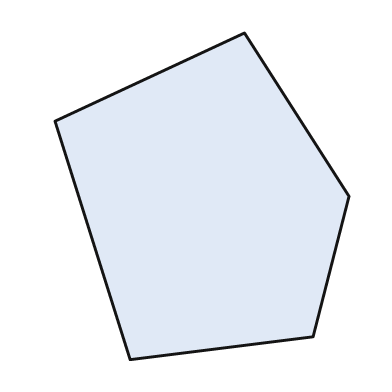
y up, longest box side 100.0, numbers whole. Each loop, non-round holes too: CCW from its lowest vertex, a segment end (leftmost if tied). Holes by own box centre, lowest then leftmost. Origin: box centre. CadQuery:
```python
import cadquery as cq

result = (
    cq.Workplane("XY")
    .moveTo(-22.0, -50.0)
    .lineTo(34.0, -43.0)
    .lineTo(45.0, 0.0)
    .lineTo(13.0, 50.0)
    .lineTo(-45.0, 23.0)
    .close()
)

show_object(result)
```